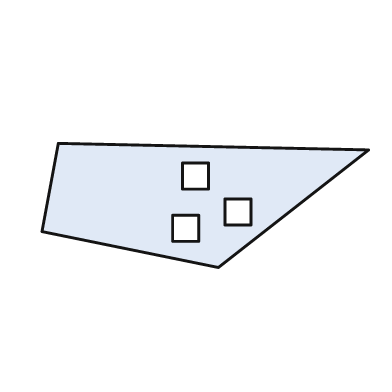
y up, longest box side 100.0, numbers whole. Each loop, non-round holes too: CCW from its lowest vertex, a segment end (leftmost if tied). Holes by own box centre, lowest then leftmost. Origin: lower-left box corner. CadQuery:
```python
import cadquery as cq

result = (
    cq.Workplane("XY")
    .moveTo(54.0, 0.0)
    .lineTo(100.0, 36.0)
    .lineTo(5.0, 38.0)
    .lineTo(0.0, 11.0)
    .close()
    .moveTo(40.0, 8.0)
    .lineTo(48.0, 8.0)
    .lineTo(48.0, 16.0)
    .lineTo(40.0, 16.0)
    .close()
    .moveTo(56.0, 13.0)
    .lineTo(64.0, 13.0)
    .lineTo(64.0, 21.0)
    .lineTo(56.0, 21.0)
    .close()
    .moveTo(43.0, 24.0)
    .lineTo(51.0, 24.0)
    .lineTo(51.0, 32.0)
    .lineTo(43.0, 32.0)
    .close()
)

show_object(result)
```